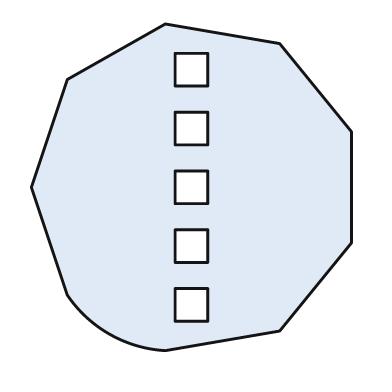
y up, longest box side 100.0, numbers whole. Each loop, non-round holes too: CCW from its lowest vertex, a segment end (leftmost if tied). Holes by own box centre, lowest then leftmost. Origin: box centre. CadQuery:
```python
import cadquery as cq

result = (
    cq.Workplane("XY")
    .moveTo(-8.0, -50.0)
    .lineTo(27.0, -44.0)
    .lineTo(49.0, -17.0)
    .lineTo(49.0, 17.0)
    .lineTo(27.0, 44.0)
    .lineTo(-8.0, 50.0)
    .lineTo(-38.0, 33.0)
    .lineTo(-49.0, 0.0)
    .lineTo(-38.0, -33.0)
    .threePointArc((-25.0, -45.0), (-8.0, -50.0))
    .close()
    .moveTo(-5.0, -41.0)
    .lineTo(5.0, -41.0)
    .lineTo(5.0, -31.0)
    .lineTo(-5.0, -31.0)
    .close()
    .moveTo(-5.0, -23.0)
    .lineTo(5.0, -23.0)
    .lineTo(5.0, -13.0)
    .lineTo(-5.0, -13.0)
    .close()
    .moveTo(-5.0, -5.0)
    .lineTo(5.0, -5.0)
    .lineTo(5.0, 5.0)
    .lineTo(-5.0, 5.0)
    .close()
    .moveTo(-5.0, 13.0)
    .lineTo(5.0, 13.0)
    .lineTo(5.0, 23.0)
    .lineTo(-5.0, 23.0)
    .close()
    .moveTo(-5.0, 31.0)
    .lineTo(5.0, 31.0)
    .lineTo(5.0, 41.0)
    .lineTo(-5.0, 41.0)
    .close()
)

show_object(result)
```